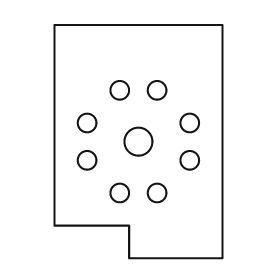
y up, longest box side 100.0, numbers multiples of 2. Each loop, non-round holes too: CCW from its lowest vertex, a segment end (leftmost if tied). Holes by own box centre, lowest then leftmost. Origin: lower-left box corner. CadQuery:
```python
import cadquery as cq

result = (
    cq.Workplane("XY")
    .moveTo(32.0, 0.0)
    .lineTo(72.0, 0.0)
    .lineTo(72.0, 100.0)
    .lineTo(0.0, 100.0)
    .lineTo(0.0, 14.0)
    .lineTo(32.0, 14.0)
    .close()
    .moveTo(28.0, 28.0)
    .circle(4.0)
    .moveTo(44.0, 28.0)
    .circle(4.0)
    .moveTo(14.0, 42.0)
    .circle(4.0)
    .moveTo(58.0, 42.0)
    .circle(4.0)
    .moveTo(36.0, 50.0)
    .circle(6.0)
    .moveTo(14.0, 58.0)
    .circle(4.0)
    .moveTo(58.0, 58.0)
    .circle(4.0)
    .moveTo(28.0, 72.0)
    .circle(4.0)
    .moveTo(44.0, 72.0)
    .circle(4.0)
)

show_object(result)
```